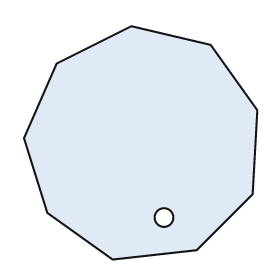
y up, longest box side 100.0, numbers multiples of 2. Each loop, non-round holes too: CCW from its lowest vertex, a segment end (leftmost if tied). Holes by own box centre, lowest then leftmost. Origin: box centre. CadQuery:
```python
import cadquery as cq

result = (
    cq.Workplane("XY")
    .moveTo(-12.0, -50.0)
    .lineTo(24.0, -46.0)
    .lineTo(48.0, -22.0)
    .lineTo(50.0, 14.0)
    .lineTo(30.0, 42.0)
    .lineTo(-4.0, 50.0)
    .lineTo(-36.0, 34.0)
    .lineTo(-50.0, 2.0)
    .lineTo(-40.0, -30.0)
    .close()
    .moveTo(10.0, -32.0)
    .circle(4.0)
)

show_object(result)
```